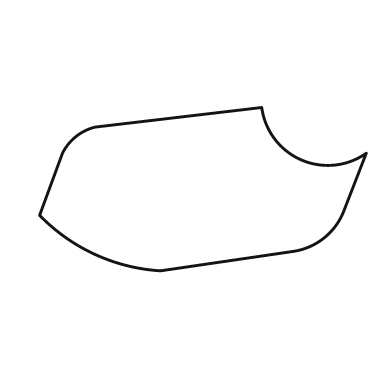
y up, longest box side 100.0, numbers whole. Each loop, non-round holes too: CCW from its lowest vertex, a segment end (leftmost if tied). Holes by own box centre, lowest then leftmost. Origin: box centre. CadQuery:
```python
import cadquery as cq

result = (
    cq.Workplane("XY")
    .moveTo(-13.0, -25.0)
    .lineTo(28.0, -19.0)
    .threePointArc((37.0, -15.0), (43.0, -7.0))
    .lineTo(50.0, 11.0)
    .threePointArc((30.0, 9.0), (18.0, 25.0))
    .lineTo(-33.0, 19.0)
    .threePointArc((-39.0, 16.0), (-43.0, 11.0))
    .lineTo(-50.0, -8.0)
    .threePointArc((-33.0, -20.0), (-13.0, -25.0))
    .close()
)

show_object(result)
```